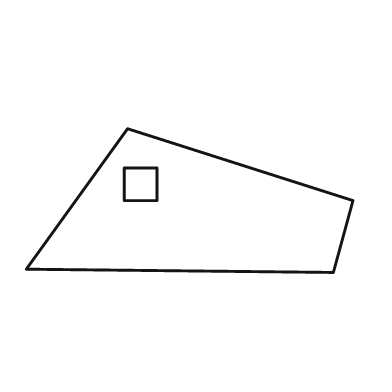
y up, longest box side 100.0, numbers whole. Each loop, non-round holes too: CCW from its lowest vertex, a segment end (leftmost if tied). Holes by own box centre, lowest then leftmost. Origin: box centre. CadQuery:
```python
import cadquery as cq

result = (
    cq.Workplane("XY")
    .moveTo(44.0, -22.0)
    .lineTo(50.0, 0.0)
    .lineTo(-19.0, 22.0)
    .lineTo(-50.0, -21.0)
    .close()
    .moveTo(-20.0, 0.0)
    .lineTo(-10.0, 0.0)
    .lineTo(-10.0, 10.0)
    .lineTo(-20.0, 10.0)
    .close()
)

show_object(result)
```